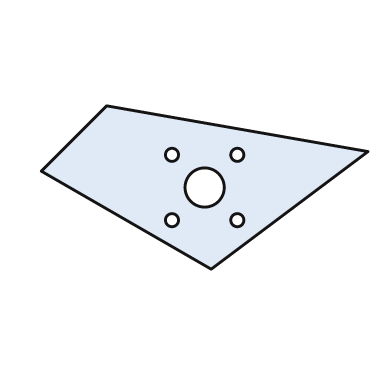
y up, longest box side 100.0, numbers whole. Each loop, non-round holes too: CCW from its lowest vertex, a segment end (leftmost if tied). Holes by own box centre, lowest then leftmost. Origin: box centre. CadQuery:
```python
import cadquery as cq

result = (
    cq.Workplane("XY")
    .moveTo(2.0, -25.0)
    .lineTo(50.0, 11.0)
    .lineTo(-30.0, 25.0)
    .lineTo(-50.0, 5.0)
    .close()
    .moveTo(-10.0, -10.0)
    .circle(2.0)
    .moveTo(10.0, -10.0)
    .circle(2.0)
    .moveTo(0.0, 0.0)
    .circle(6.0)
    .moveTo(-10.0, 10.0)
    .circle(2.0)
    .moveTo(10.0, 10.0)
    .circle(2.0)
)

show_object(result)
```